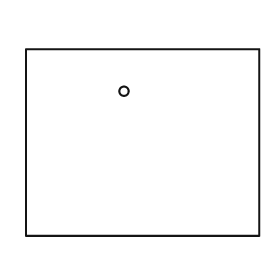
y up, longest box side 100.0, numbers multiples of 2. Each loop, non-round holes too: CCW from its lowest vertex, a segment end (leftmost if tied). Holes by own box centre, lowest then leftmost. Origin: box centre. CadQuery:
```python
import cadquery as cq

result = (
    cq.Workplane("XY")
    .moveTo(-50.0, -40.0)
    .lineTo(50.0, -40.0)
    .lineTo(50.0, 40.0)
    .lineTo(-50.0, 40.0)
    .close()
    .moveTo(-8.0, 22.0)
    .circle(2.0)
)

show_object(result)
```